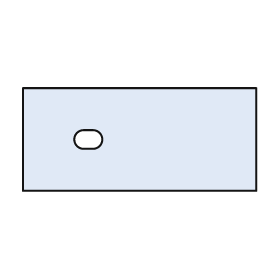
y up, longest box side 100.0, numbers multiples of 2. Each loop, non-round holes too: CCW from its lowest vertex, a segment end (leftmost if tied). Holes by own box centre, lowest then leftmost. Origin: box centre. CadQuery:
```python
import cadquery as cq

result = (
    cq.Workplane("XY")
    .moveTo(-50.0, -22.0)
    .lineTo(50.0, -22.0)
    .lineTo(50.0, 22.0)
    .lineTo(-50.0, 22.0)
    .close()
    .moveTo(-24.0, -4.0)
    .lineTo(-20.0, -4.0)
    .threePointArc((-16.0, 0.0), (-20.0, 4.0))
    .lineTo(-24.0, 4.0)
    .threePointArc((-28.0, 0.0), (-24.0, -4.0))
    .close()
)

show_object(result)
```